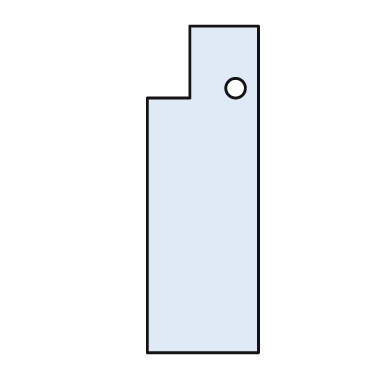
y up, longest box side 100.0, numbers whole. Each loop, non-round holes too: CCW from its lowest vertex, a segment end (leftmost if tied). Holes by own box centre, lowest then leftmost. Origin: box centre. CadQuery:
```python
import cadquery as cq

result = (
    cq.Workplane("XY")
    .moveTo(-17.0, -50.0)
    .lineTo(17.0, -50.0)
    .lineTo(17.0, 50.0)
    .lineTo(-4.0, 50.0)
    .lineTo(-4.0, 28.0)
    .lineTo(-17.0, 28.0)
    .close()
    .moveTo(10.0, 31.0)
    .circle(3.0)
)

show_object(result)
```